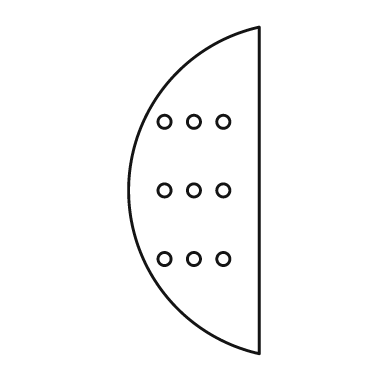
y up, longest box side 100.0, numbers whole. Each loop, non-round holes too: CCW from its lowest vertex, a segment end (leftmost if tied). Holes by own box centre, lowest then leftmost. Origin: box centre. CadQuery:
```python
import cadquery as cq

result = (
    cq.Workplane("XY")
    .moveTo(20.0, -50.0)
    .lineTo(20.0, 50.0)
    .threePointArc((-20.0, 0.0), (20.0, -50.0))
    .close()
    .moveTo(-9.0, -21.0)
    .circle(2.0)
    .moveTo(0.0, -21.0)
    .circle(2.0)
    .moveTo(9.0, -21.0)
    .circle(2.0)
    .moveTo(-9.0, 0.0)
    .circle(2.0)
    .moveTo(0.0, 0.0)
    .circle(2.0)
    .moveTo(9.0, 0.0)
    .circle(2.0)
    .moveTo(-9.0, 21.0)
    .circle(2.0)
    .moveTo(0.0, 21.0)
    .circle(2.0)
    .moveTo(9.0, 21.0)
    .circle(2.0)
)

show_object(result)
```